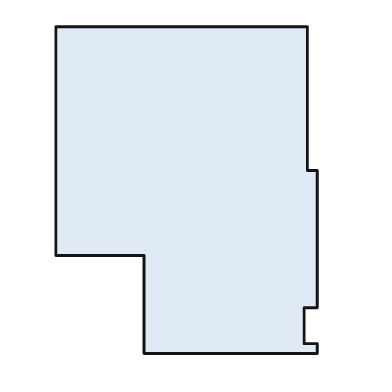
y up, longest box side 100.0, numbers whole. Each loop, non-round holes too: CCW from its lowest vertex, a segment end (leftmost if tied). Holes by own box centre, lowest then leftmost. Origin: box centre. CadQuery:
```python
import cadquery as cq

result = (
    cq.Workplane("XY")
    .moveTo(-13.0, -50.0)
    .lineTo(40.0, -50.0)
    .lineTo(40.0, -47.0)
    .lineTo(36.0, -47.0)
    .lineTo(36.0, -36.0)
    .lineTo(40.0, -36.0)
    .lineTo(40.0, 6.0)
    .lineTo(37.0, 6.0)
    .lineTo(37.0, 50.0)
    .lineTo(-40.0, 50.0)
    .lineTo(-40.0, -20.0)
    .lineTo(-13.0, -20.0)
    .close()
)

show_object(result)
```